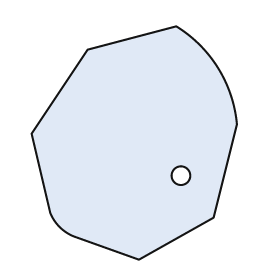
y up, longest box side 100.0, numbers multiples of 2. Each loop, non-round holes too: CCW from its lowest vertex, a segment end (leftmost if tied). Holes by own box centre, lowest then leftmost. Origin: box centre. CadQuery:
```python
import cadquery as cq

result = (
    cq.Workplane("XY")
    .moveTo(2.0, -50.0)
    .lineTo(34.0, -32.0)
    .lineTo(44.0, 8.0)
    .threePointArc((36.0, 32.0), (18.0, 50.0))
    .lineTo(-20.0, 40.0)
    .lineTo(-44.0, 4.0)
    .lineTo(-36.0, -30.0)
    .threePointArc((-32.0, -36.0), (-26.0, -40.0))
    .close()
    .moveTo(20.0, -14.0)
    .circle(4.0)
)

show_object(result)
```